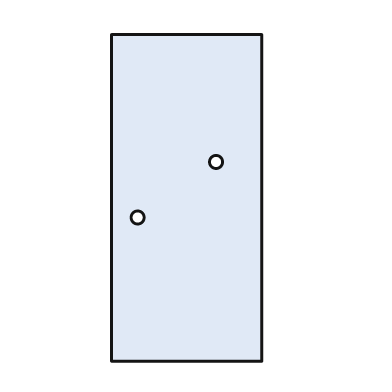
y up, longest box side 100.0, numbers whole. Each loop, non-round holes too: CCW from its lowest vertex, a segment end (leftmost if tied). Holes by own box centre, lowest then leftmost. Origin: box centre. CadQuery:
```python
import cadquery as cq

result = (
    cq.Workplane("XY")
    .moveTo(-23.0, -50.0)
    .lineTo(23.0, -50.0)
    .lineTo(23.0, 50.0)
    .lineTo(-23.0, 50.0)
    .close()
    .moveTo(-15.0, -6.0)
    .circle(2.0)
    .moveTo(9.0, 11.0)
    .circle(2.0)
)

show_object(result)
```